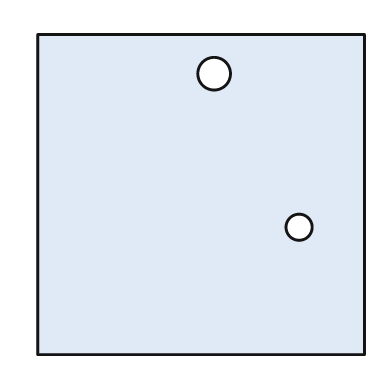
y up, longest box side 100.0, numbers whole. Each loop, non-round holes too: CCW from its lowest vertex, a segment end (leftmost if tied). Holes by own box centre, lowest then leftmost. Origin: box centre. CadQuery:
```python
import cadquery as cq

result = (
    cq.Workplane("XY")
    .moveTo(-50.0, -49.0)
    .lineTo(50.0, -49.0)
    .lineTo(50.0, 49.0)
    .lineTo(-50.0, 49.0)
    .close()
    .moveTo(30.0, -10.0)
    .circle(4.0)
    .moveTo(4.0, 37.0)
    .circle(5.0)
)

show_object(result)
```